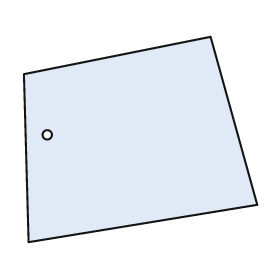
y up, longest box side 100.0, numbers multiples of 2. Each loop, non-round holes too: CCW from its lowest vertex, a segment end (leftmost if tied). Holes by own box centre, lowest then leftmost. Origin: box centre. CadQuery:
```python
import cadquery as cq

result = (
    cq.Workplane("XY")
    .moveTo(-48.0, -44.0)
    .lineTo(50.0, -28.0)
    .lineTo(30.0, 44.0)
    .lineTo(-50.0, 28.0)
    .close()
    .moveTo(-40.0, 2.0)
    .circle(2.0)
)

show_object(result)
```